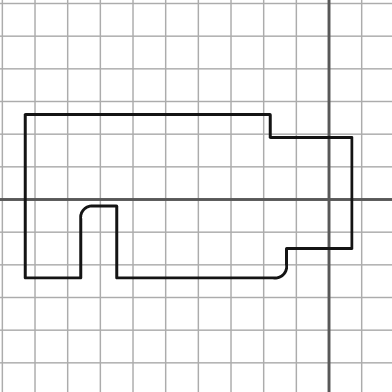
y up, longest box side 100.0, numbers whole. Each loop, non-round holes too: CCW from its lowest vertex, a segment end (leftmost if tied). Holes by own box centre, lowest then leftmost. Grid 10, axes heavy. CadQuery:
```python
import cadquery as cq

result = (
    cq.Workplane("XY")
    .moveTo(-93.0, -24.0)
    .lineTo(-76.0, -24.0)
    .lineTo(-76.0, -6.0)
    .threePointArc((-75.0, -3.0), (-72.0, -2.0))
    .lineTo(-65.0, -2.0)
    .lineTo(-65.0, -24.0)
    .lineTo(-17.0, -24.0)
    .threePointArc((-14.0, -23.0), (-13.0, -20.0))
    .lineTo(-13.0, -15.0)
    .lineTo(7.0, -15.0)
    .lineTo(7.0, 19.0)
    .lineTo(-18.0, 19.0)
    .lineTo(-18.0, 26.0)
    .lineTo(-93.0, 26.0)
    .close()
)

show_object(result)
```